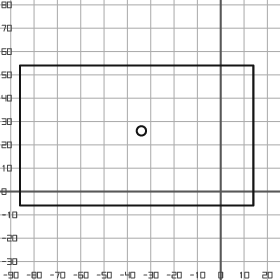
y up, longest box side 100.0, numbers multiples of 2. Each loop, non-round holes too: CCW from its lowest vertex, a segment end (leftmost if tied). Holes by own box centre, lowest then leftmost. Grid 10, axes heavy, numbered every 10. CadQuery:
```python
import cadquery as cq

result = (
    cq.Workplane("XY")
    .moveTo(-86.0, -6.0)
    .lineTo(14.0, -6.0)
    .lineTo(14.0, 54.0)
    .lineTo(-86.0, 54.0)
    .close()
    .moveTo(-34.0, 26.0)
    .circle(2.0)
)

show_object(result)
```